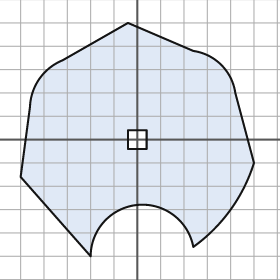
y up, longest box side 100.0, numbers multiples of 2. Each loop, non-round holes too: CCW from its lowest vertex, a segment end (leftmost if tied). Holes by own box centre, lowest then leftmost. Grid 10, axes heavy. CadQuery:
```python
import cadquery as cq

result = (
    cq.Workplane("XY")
    .moveTo(-20.0, -50.0)
    .threePointArc((0.0, -28.0), (24.0, -46.0))
    .threePointArc((40.0, -30.0), (50.0, -10.0))
    .lineTo(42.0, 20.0)
    .threePointArc((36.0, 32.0), (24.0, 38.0))
    .lineTo(-4.0, 50.0)
    .lineTo(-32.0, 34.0)
    .threePointArc((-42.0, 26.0), (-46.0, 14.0))
    .lineTo(-50.0, -16.0)
    .close()
    .moveTo(-4.0, -4.0)
    .lineTo(4.0, -4.0)
    .lineTo(4.0, 4.0)
    .lineTo(-4.0, 4.0)
    .close()
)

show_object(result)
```